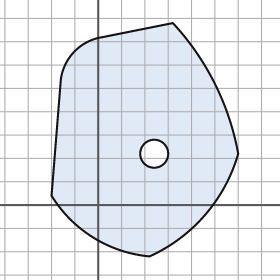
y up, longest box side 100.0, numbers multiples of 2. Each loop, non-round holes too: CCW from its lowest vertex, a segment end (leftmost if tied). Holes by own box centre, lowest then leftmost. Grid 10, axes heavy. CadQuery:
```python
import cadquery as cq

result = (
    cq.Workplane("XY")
    .moveTo(22.0, -22.0)
    .threePointArc((46.0, -4.0), (60.0, 22.0))
    .threePointArc((50.0, 52.0), (32.0, 78.0))
    .lineTo(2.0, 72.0)
    .threePointArc((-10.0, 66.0), (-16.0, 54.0))
    .lineTo(-20.0, 4.0)
    .threePointArc((-2.0, -14.0), (22.0, -22.0))
    .close()
    .moveTo(24.0, 22.0)
    .circle(6.0)
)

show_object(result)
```